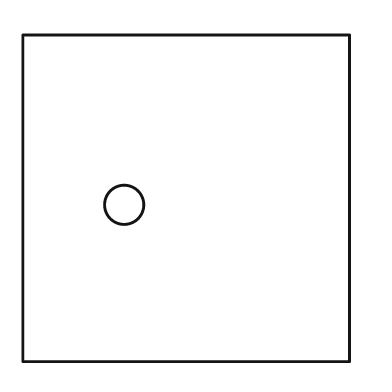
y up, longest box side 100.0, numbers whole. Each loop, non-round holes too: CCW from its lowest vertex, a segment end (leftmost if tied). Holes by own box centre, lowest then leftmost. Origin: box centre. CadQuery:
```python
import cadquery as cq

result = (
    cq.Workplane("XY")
    .moveTo(-50.0, -50.0)
    .lineTo(50.0, -50.0)
    .lineTo(50.0, 50.0)
    .lineTo(-50.0, 50.0)
    .close()
    .moveTo(-19.0, -2.0)
    .circle(6.0)
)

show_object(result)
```